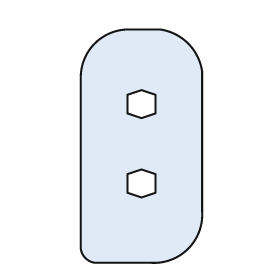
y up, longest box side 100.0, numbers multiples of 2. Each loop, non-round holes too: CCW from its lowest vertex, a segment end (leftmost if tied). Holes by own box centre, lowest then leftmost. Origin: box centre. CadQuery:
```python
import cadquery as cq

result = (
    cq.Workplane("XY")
    .moveTo(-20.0, -50.0)
    .lineTo(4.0, -50.0)
    .threePointArc((20.0, -44.0), (26.0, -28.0))
    .lineTo(26.0, 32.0)
    .threePointArc((20.0, 44.0), (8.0, 50.0))
    .lineTo(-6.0, 50.0)
    .threePointArc((-20.0, 44.0), (-26.0, 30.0))
    .lineTo(-26.0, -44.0)
    .threePointArc((-24.0, -48.0), (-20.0, -50.0))
    .close()
    .moveTo(0.0, -22.0)
    .lineTo(6.0, -20.0)
    .lineTo(6.0, -12.0)
    .lineTo(0.0, -10.0)
    .lineTo(-6.0, -12.0)
    .lineTo(-6.0, -20.0)
    .close()
    .moveTo(0.0, 12.0)
    .lineTo(6.0, 14.0)
    .lineTo(6.0, 22.0)
    .lineTo(0.0, 24.0)
    .lineTo(-6.0, 22.0)
    .lineTo(-6.0, 14.0)
    .close()
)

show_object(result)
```